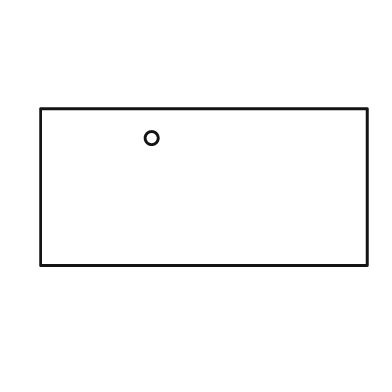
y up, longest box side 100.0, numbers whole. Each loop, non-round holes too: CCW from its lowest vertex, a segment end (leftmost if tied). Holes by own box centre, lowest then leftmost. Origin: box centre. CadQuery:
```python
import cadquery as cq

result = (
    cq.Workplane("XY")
    .moveTo(-50.0, -24.0)
    .lineTo(50.0, -24.0)
    .lineTo(50.0, 24.0)
    .lineTo(-50.0, 24.0)
    .close()
    .moveTo(-16.0, 15.0)
    .circle(2.0)
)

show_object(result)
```